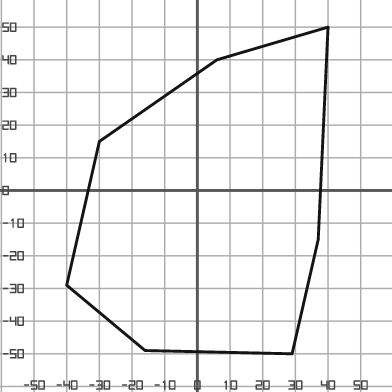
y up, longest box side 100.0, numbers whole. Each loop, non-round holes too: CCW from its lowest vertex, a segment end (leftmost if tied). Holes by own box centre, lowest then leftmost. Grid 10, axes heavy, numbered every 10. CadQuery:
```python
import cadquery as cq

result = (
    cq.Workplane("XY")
    .moveTo(29.0, -50.0)
    .lineTo(37.0, -15.0)
    .lineTo(40.0, 50.0)
    .lineTo(6.0, 40.0)
    .lineTo(-30.0, 15.0)
    .lineTo(-40.0, -29.0)
    .lineTo(-16.0, -49.0)
    .close()
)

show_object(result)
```